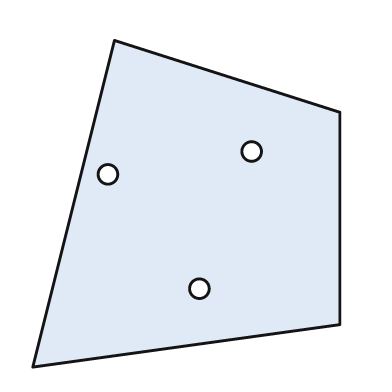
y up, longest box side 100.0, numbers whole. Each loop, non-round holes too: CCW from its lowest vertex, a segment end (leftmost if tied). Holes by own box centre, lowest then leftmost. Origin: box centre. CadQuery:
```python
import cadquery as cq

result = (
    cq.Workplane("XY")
    .moveTo(-47.0, -50.0)
    .lineTo(47.0, -37.0)
    .lineTo(47.0, 28.0)
    .lineTo(-22.0, 50.0)
    .close()
    .moveTo(4.0, -26.0)
    .circle(3.0)
    .moveTo(-24.0, 9.0)
    .circle(3.0)
    .moveTo(20.0, 16.0)
    .circle(3.0)
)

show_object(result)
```